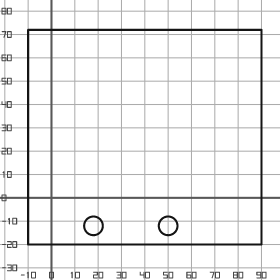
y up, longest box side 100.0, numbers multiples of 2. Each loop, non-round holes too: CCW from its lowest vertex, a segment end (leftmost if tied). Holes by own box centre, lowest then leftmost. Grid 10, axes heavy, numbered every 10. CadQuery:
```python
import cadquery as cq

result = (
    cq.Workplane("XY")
    .moveTo(-10.0, -20.0)
    .lineTo(90.0, -20.0)
    .lineTo(90.0, 72.0)
    .lineTo(-10.0, 72.0)
    .close()
    .moveTo(18.0, -12.0)
    .circle(4.0)
    .moveTo(50.0, -12.0)
    .circle(4.0)
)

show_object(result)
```